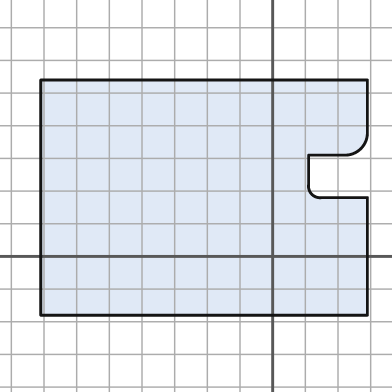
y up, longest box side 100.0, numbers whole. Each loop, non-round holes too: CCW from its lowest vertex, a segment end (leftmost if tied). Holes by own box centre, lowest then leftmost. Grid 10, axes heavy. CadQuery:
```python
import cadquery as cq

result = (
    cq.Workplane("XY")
    .moveTo(-71.0, -18.0)
    .lineTo(29.0, -18.0)
    .lineTo(29.0, 18.0)
    .lineTo(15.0, 18.0)
    .threePointArc((12.0, 19.0), (11.0, 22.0))
    .lineTo(11.0, 31.0)
    .lineTo(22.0, 31.0)
    .threePointArc((27.0, 33.0), (29.0, 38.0))
    .lineTo(29.0, 54.0)
    .lineTo(-71.0, 54.0)
    .close()
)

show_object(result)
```